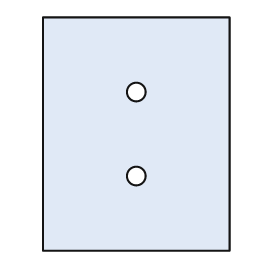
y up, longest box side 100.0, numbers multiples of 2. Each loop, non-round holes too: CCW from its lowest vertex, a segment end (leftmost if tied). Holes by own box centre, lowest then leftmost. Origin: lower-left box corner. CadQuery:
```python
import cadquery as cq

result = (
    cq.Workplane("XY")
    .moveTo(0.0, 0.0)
    .lineTo(80.0, 0.0)
    .lineTo(80.0, 100.0)
    .lineTo(0.0, 100.0)
    .close()
    .moveTo(40.0, 32.0)
    .circle(4.0)
    .moveTo(40.0, 68.0)
    .circle(4.0)
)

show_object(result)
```